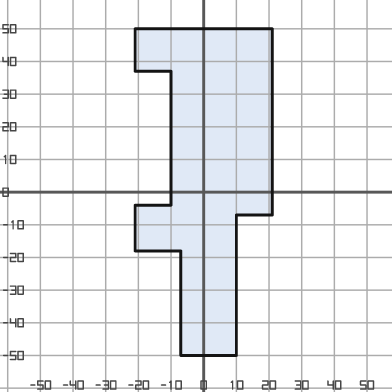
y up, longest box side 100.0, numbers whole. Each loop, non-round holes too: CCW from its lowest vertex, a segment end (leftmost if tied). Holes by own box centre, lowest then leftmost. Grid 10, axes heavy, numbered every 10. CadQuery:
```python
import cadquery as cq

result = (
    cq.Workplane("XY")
    .moveTo(-7.0, -50.0)
    .lineTo(10.0, -50.0)
    .lineTo(10.0, -7.0)
    .lineTo(21.0, -7.0)
    .lineTo(21.0, 50.0)
    .lineTo(-21.0, 50.0)
    .lineTo(-21.0, 37.0)
    .lineTo(-10.0, 37.0)
    .lineTo(-10.0, -4.0)
    .lineTo(-21.0, -4.0)
    .lineTo(-21.0, -18.0)
    .lineTo(-7.0, -18.0)
    .close()
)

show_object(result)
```